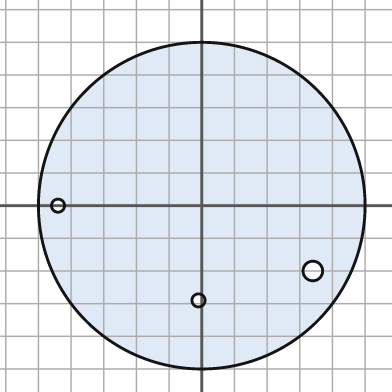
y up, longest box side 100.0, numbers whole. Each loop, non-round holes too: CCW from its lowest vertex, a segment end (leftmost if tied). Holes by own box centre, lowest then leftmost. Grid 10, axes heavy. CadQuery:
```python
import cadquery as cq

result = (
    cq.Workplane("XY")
    .moveTo(0.0, 0.0)
    .circle(50.0)
    .moveTo(-1.0, -29.0)
    .circle(2.0)
    .moveTo(34.0, -20.0)
    .circle(3.0)
    .moveTo(-44.0, 0.0)
    .circle(2.0)
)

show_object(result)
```